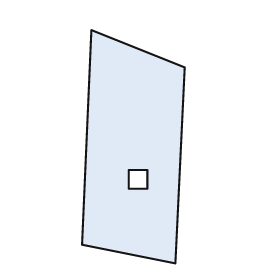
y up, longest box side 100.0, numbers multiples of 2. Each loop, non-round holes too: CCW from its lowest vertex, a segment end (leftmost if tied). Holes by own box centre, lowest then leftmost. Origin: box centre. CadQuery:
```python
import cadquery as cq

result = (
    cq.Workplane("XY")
    .moveTo(18.0, -50.0)
    .lineTo(22.0, 34.0)
    .lineTo(-18.0, 50.0)
    .lineTo(-22.0, -42.0)
    .close()
    .moveTo(-2.0, -18.0)
    .lineTo(6.0, -18.0)
    .lineTo(6.0, -10.0)
    .lineTo(-2.0, -10.0)
    .close()
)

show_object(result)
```